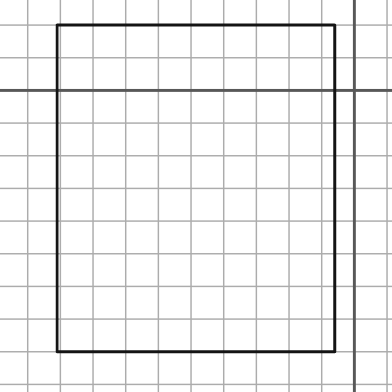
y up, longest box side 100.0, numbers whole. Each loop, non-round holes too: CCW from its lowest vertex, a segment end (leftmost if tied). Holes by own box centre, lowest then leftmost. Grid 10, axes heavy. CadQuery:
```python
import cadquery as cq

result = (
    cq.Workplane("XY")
    .moveTo(-91.0, -80.0)
    .lineTo(-6.0, -80.0)
    .lineTo(-6.0, 20.0)
    .lineTo(-91.0, 20.0)
    .close()
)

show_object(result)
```